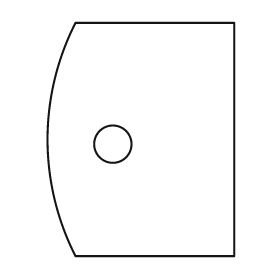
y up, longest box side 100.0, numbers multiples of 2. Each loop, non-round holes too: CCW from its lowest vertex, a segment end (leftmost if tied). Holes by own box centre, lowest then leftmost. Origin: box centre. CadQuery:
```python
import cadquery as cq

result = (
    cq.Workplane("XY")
    .moveTo(-28.0, -50.0)
    .lineTo(40.0, -50.0)
    .lineTo(40.0, 50.0)
    .lineTo(-28.0, 50.0)
    .threePointArc((-40.0, 0.0), (-28.0, -50.0))
    .close()
    .moveTo(-12.0, -2.0)
    .circle(8.0)
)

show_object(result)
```